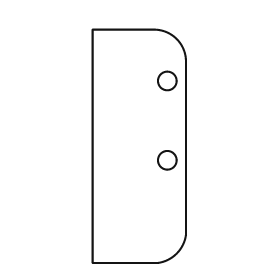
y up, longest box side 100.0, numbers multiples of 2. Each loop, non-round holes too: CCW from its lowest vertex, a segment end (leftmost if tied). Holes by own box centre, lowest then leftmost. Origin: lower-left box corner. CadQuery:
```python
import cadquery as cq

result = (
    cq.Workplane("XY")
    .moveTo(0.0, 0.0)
    .lineTo(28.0, 0.0)
    .threePointArc((36.0, 4.0), (40.0, 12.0))
    .lineTo(40.0, 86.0)
    .threePointArc((36.0, 96.0), (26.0, 100.0))
    .lineTo(0.0, 100.0)
    .close()
    .moveTo(32.0, 44.0)
    .circle(4.0)
    .moveTo(32.0, 78.0)
    .circle(4.0)
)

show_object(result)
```